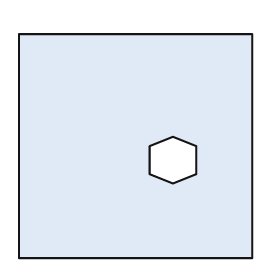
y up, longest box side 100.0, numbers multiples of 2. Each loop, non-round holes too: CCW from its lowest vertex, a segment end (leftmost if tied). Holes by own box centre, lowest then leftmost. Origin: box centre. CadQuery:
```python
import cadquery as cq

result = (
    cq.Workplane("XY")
    .moveTo(-50.0, -48.0)
    .lineTo(50.0, -48.0)
    .lineTo(50.0, 48.0)
    .lineTo(-50.0, 48.0)
    .close()
    .moveTo(16.0, -16.0)
    .lineTo(26.0, -12.0)
    .lineTo(26.0, 0.0)
    .lineTo(16.0, 4.0)
    .lineTo(6.0, 0.0)
    .lineTo(6.0, -12.0)
    .close()
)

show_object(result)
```